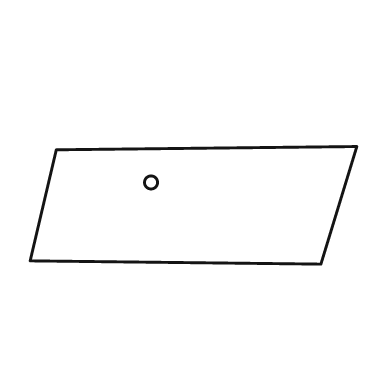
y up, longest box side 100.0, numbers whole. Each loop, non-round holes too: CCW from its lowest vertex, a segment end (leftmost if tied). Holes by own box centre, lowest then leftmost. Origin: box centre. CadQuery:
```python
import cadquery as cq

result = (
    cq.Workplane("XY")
    .moveTo(39.0, -18.0)
    .lineTo(50.0, 18.0)
    .lineTo(-42.0, 17.0)
    .lineTo(-50.0, -17.0)
    .close()
    .moveTo(-13.0, 7.0)
    .circle(2.0)
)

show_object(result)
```